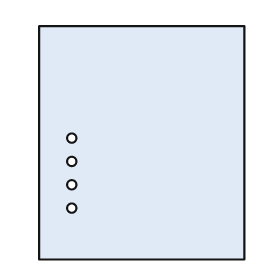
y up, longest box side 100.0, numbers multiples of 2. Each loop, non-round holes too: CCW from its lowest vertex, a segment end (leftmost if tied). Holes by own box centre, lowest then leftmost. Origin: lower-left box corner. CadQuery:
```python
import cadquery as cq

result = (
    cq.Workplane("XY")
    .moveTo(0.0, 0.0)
    .lineTo(88.0, 0.0)
    .lineTo(88.0, 100.0)
    .lineTo(0.0, 100.0)
    .close()
    .moveTo(14.0, 22.0)
    .circle(2.0)
    .moveTo(14.0, 32.0)
    .circle(2.0)
    .moveTo(14.0, 42.0)
    .circle(2.0)
    .moveTo(14.0, 52.0)
    .circle(2.0)
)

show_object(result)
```